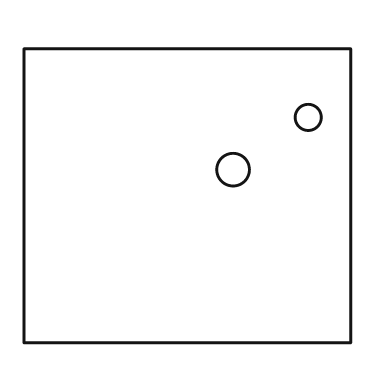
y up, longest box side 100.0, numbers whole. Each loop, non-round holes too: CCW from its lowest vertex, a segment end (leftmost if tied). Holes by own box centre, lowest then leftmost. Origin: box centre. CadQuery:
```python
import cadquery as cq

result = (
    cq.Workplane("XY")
    .moveTo(-50.0, -45.0)
    .lineTo(50.0, -45.0)
    .lineTo(50.0, 45.0)
    .lineTo(-50.0, 45.0)
    .close()
    .moveTo(14.0, 8.0)
    .circle(5.0)
    .moveTo(37.0, 24.0)
    .circle(4.0)
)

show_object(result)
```